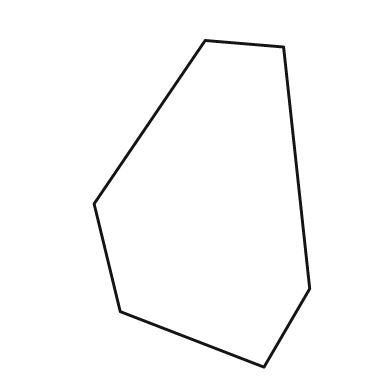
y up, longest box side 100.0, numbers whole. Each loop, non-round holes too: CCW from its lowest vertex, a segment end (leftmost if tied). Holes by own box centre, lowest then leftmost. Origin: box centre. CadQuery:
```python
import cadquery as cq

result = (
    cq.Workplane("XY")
    .moveTo(19.0, -50.0)
    .lineTo(33.0, -26.0)
    .lineTo(25.0, 48.0)
    .lineTo(1.0, 50.0)
    .lineTo(-33.0, 0.0)
    .lineTo(-25.0, -33.0)
    .close()
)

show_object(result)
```